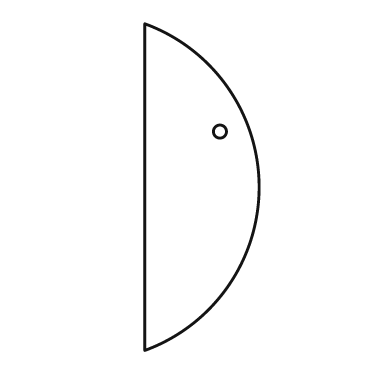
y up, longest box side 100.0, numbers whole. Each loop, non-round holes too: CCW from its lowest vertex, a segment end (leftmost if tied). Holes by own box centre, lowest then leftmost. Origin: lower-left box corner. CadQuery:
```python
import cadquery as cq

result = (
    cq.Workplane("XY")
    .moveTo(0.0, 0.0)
    .threePointArc((35.0, 50.0), (0.0, 100.0))
    .close()
    .moveTo(23.0, 67.0)
    .circle(2.0)
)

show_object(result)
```